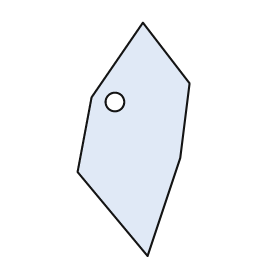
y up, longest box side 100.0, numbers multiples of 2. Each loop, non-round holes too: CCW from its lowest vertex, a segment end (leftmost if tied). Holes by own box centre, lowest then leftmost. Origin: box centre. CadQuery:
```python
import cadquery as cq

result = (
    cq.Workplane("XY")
    .moveTo(6.0, -50.0)
    .lineTo(20.0, -8.0)
    .lineTo(24.0, 24.0)
    .lineTo(4.0, 50.0)
    .lineTo(-18.0, 18.0)
    .lineTo(-24.0, -14.0)
    .close()
    .moveTo(-8.0, 16.0)
    .circle(4.0)
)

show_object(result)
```